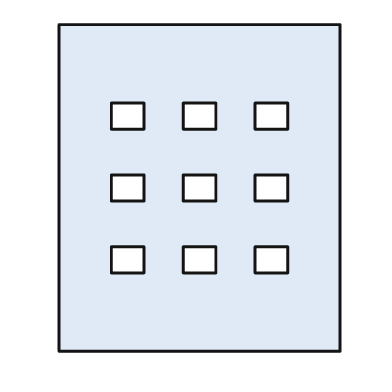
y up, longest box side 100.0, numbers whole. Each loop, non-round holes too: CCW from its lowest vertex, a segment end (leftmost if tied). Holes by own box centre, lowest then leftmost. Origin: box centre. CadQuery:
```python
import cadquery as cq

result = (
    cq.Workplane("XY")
    .moveTo(-43.0, -50.0)
    .lineTo(43.0, -50.0)
    .lineTo(43.0, 50.0)
    .lineTo(-43.0, 50.0)
    .close()
    .moveTo(-27.0, -26.0)
    .lineTo(-17.0, -26.0)
    .lineTo(-17.0, -18.0)
    .lineTo(-27.0, -18.0)
    .close()
    .moveTo(-5.0, -26.0)
    .lineTo(5.0, -26.0)
    .lineTo(5.0, -18.0)
    .lineTo(-5.0, -18.0)
    .close()
    .moveTo(17.0, -26.0)
    .lineTo(27.0, -26.0)
    .lineTo(27.0, -18.0)
    .lineTo(17.0, -18.0)
    .close()
    .moveTo(-27.0, -4.0)
    .lineTo(-17.0, -4.0)
    .lineTo(-17.0, 4.0)
    .lineTo(-27.0, 4.0)
    .close()
    .moveTo(-5.0, -4.0)
    .lineTo(5.0, -4.0)
    .lineTo(5.0, 4.0)
    .lineTo(-5.0, 4.0)
    .close()
    .moveTo(17.0, -4.0)
    .lineTo(27.0, -4.0)
    .lineTo(27.0, 4.0)
    .lineTo(17.0, 4.0)
    .close()
    .moveTo(-27.0, 18.0)
    .lineTo(-17.0, 18.0)
    .lineTo(-17.0, 26.0)
    .lineTo(-27.0, 26.0)
    .close()
    .moveTo(-5.0, 18.0)
    .lineTo(5.0, 18.0)
    .lineTo(5.0, 26.0)
    .lineTo(-5.0, 26.0)
    .close()
    .moveTo(17.0, 18.0)
    .lineTo(27.0, 18.0)
    .lineTo(27.0, 26.0)
    .lineTo(17.0, 26.0)
    .close()
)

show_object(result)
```